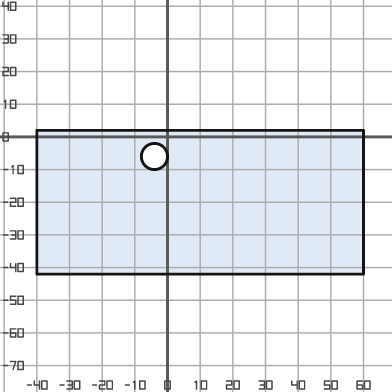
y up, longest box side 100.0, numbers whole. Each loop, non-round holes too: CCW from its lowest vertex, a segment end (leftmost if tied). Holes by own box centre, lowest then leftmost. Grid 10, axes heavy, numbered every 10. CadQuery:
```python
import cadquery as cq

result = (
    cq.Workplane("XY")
    .moveTo(-40.0, -42.0)
    .lineTo(60.0, -42.0)
    .lineTo(60.0, 2.0)
    .lineTo(-40.0, 2.0)
    .close()
    .moveTo(-4.0, -6.0)
    .circle(4.0)
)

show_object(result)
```